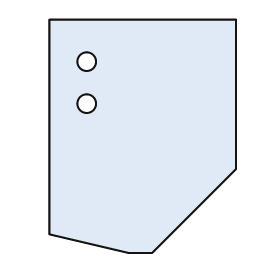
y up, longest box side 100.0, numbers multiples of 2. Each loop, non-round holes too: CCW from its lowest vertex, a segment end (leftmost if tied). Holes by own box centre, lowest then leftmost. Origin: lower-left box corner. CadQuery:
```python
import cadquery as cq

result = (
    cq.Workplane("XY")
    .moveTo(34.0, 0.0)
    .lineTo(44.0, 0.0)
    .lineTo(80.0, 36.0)
    .lineTo(80.0, 100.0)
    .lineTo(0.0, 100.0)
    .lineTo(0.0, 8.0)
    .close()
    .moveTo(16.0, 64.0)
    .circle(4.0)
    .moveTo(16.0, 82.0)
    .circle(4.0)
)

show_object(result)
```